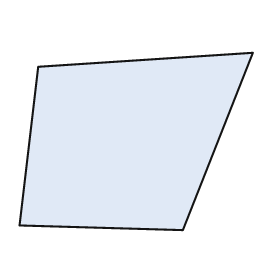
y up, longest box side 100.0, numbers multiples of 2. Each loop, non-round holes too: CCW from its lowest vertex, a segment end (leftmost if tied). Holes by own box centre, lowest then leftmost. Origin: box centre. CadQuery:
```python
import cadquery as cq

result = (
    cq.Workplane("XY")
    .moveTo(20.0, -38.0)
    .lineTo(50.0, 38.0)
    .lineTo(-42.0, 32.0)
    .lineTo(-50.0, -36.0)
    .close()
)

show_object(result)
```